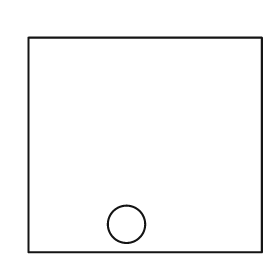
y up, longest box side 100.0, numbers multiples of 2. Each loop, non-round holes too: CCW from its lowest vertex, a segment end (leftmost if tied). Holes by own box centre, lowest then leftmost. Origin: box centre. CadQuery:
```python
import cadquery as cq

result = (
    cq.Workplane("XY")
    .moveTo(-50.0, -46.0)
    .lineTo(50.0, -46.0)
    .lineTo(50.0, 46.0)
    .lineTo(-50.0, 46.0)
    .close()
    .moveTo(-8.0, -34.0)
    .circle(8.0)
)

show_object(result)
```